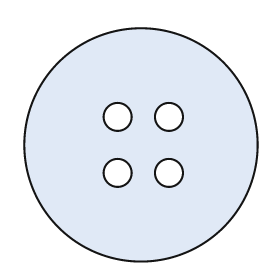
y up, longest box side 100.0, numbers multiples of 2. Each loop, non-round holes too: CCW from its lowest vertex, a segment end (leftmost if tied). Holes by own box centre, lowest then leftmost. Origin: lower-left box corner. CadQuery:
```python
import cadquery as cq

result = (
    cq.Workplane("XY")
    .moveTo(50.0, 50.0)
    .circle(50.0)
    .moveTo(40.0, 38.0)
    .circle(6.0)
    .moveTo(62.0, 38.0)
    .circle(6.0)
    .moveTo(40.0, 62.0)
    .circle(6.0)
    .moveTo(62.0, 62.0)
    .circle(6.0)
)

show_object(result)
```